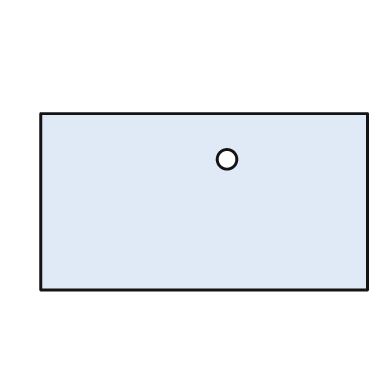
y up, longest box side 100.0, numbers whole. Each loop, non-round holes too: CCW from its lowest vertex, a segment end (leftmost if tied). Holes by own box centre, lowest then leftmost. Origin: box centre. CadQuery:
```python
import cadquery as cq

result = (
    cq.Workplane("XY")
    .moveTo(-50.0, -27.0)
    .lineTo(50.0, -27.0)
    .lineTo(50.0, 27.0)
    .lineTo(-50.0, 27.0)
    .close()
    .moveTo(7.0, 13.0)
    .circle(3.0)
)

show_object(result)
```